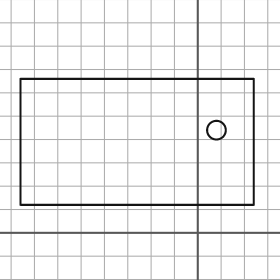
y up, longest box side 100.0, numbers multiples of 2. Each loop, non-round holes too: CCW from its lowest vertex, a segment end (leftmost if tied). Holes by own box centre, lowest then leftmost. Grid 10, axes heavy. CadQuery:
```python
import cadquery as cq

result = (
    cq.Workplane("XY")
    .moveTo(-76.0, 12.0)
    .lineTo(24.0, 12.0)
    .lineTo(24.0, 66.0)
    .lineTo(-76.0, 66.0)
    .close()
    .moveTo(8.0, 44.0)
    .circle(4.0)
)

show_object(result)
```